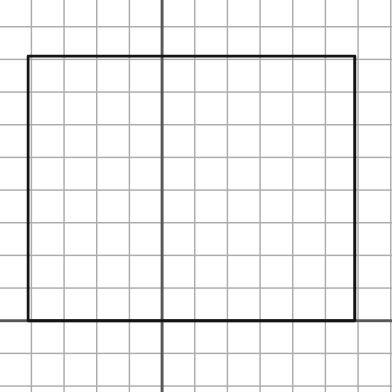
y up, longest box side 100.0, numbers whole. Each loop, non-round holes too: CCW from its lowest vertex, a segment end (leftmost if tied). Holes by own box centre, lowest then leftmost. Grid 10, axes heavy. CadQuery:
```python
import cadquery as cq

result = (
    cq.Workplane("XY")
    .moveTo(-41.0, 0.0)
    .lineTo(59.0, 0.0)
    .lineTo(59.0, 81.0)
    .lineTo(-41.0, 81.0)
    .close()
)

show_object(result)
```